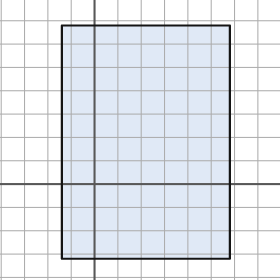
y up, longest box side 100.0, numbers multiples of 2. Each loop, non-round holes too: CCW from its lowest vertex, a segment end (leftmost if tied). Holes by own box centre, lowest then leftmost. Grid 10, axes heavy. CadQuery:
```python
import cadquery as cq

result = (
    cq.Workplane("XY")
    .moveTo(-14.0, -32.0)
    .lineTo(58.0, -32.0)
    .lineTo(58.0, 68.0)
    .lineTo(-14.0, 68.0)
    .close()
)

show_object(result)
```